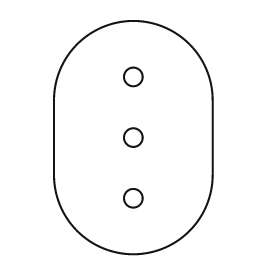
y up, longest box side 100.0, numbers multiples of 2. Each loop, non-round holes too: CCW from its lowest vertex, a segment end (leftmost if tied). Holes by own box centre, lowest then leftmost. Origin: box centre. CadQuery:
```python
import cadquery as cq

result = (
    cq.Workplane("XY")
    .moveTo(-34.0, -16.0)
    .threePointArc((0.0, -50.0), (34.0, -16.0))
    .lineTo(34.0, 16.0)
    .threePointArc((0.0, 50.0), (-34.0, 16.0))
    .close()
    .moveTo(0.0, -26.0)
    .circle(4.0)
    .moveTo(0.0, 0.0)
    .circle(4.0)
    .moveTo(0.0, 26.0)
    .circle(4.0)
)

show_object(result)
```